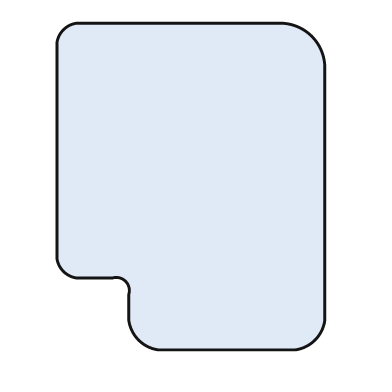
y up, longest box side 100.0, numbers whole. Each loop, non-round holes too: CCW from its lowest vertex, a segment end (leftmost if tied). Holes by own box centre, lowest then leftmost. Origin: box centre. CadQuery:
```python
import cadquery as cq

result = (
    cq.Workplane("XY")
    .moveTo(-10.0, -50.0)
    .lineTo(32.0, -50.0)
    .threePointArc((38.0, -47.0), (41.0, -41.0))
    .lineTo(41.0, 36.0)
    .threePointArc((37.0, 46.0), (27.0, 50.0))
    .lineTo(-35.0, 50.0)
    .threePointArc((-39.0, 48.0), (-41.0, 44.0))
    .lineTo(-41.0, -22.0)
    .threePointArc((-39.0, -26.0), (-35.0, -28.0))
    .lineTo(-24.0, -28.0)
    .threePointArc((-20.0, -29.0), (-19.0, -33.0))
    .lineTo(-19.0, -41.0)
    .threePointArc((-16.0, -47.0), (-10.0, -50.0))
    .close()
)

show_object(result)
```